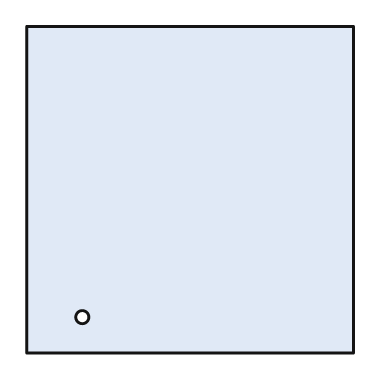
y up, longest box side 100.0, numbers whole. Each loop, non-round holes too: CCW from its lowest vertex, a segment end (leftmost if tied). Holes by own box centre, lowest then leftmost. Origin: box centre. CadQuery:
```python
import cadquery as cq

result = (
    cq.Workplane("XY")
    .moveTo(-50.0, -50.0)
    .lineTo(50.0, -50.0)
    .lineTo(50.0, 50.0)
    .lineTo(-50.0, 50.0)
    .close()
    .moveTo(-33.0, -39.0)
    .circle(2.0)
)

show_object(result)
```